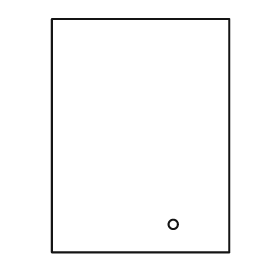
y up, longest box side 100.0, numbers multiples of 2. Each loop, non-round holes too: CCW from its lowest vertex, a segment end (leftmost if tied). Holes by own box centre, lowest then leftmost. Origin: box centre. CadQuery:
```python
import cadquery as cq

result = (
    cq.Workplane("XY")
    .moveTo(-38.0, -50.0)
    .lineTo(38.0, -50.0)
    .lineTo(38.0, 50.0)
    .lineTo(-38.0, 50.0)
    .close()
    .moveTo(14.0, -38.0)
    .circle(2.0)
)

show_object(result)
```